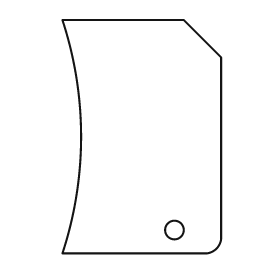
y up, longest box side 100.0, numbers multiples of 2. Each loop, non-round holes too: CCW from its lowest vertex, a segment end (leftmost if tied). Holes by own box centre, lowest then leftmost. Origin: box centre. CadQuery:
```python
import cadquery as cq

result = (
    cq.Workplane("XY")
    .moveTo(-34.0, -50.0)
    .lineTo(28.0, -50.0)
    .threePointArc((32.0, -48.0), (34.0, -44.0))
    .lineTo(34.0, 34.0)
    .lineTo(18.0, 50.0)
    .lineTo(-34.0, 50.0)
    .threePointArc((-26.0, 0.0), (-34.0, -50.0))
    .close()
    .moveTo(14.0, -40.0)
    .circle(4.0)
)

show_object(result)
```